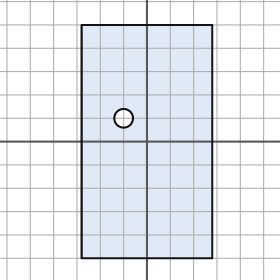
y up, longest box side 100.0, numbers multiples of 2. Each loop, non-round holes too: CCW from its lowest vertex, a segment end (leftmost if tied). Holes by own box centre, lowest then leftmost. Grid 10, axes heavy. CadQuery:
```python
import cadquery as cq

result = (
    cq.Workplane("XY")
    .moveTo(-28.0, -50.0)
    .lineTo(28.0, -50.0)
    .lineTo(28.0, 50.0)
    .lineTo(-28.0, 50.0)
    .close()
    .moveTo(-10.0, 10.0)
    .circle(4.0)
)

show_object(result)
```